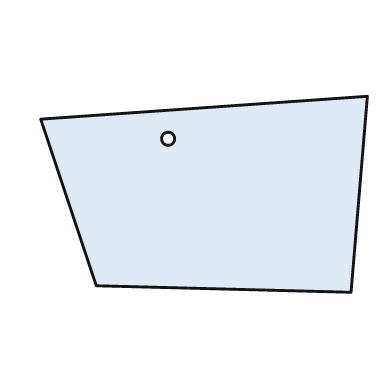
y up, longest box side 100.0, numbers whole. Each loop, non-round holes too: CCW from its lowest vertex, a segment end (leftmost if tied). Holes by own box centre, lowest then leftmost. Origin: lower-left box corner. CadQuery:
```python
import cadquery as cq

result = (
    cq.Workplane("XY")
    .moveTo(95.0, 0.0)
    .lineTo(100.0, 60.0)
    .lineTo(0.0, 53.0)
    .lineTo(17.0, 2.0)
    .close()
    .moveTo(39.0, 47.0)
    .circle(2.0)
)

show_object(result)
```